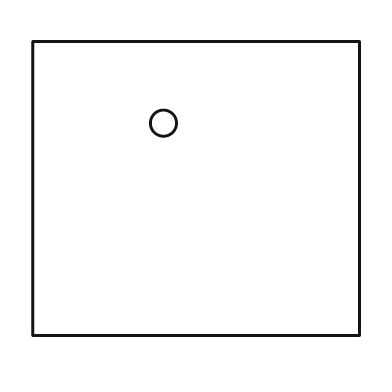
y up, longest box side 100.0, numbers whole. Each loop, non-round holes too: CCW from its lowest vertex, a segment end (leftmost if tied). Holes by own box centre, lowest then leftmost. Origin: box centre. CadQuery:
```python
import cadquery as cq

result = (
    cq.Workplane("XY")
    .moveTo(-50.0, -45.0)
    .lineTo(50.0, -45.0)
    .lineTo(50.0, 45.0)
    .lineTo(-50.0, 45.0)
    .close()
    .moveTo(-10.0, 20.0)
    .circle(4.0)
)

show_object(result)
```